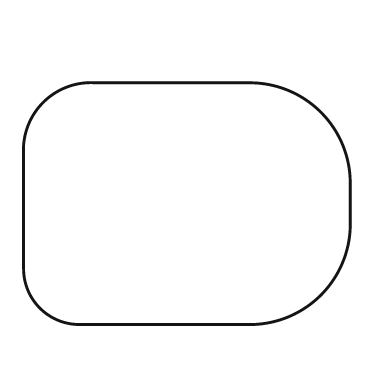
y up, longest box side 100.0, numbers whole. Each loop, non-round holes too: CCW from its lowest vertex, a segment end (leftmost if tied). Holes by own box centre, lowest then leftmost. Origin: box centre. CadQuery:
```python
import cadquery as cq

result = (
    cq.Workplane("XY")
    .moveTo(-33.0, -37.0)
    .lineTo(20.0, -37.0)
    .threePointArc((41.0, -28.0), (50.0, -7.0))
    .lineTo(50.0, 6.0)
    .threePointArc((41.0, 28.0), (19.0, 37.0))
    .lineTo(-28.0, 37.0)
    .threePointArc((-44.0, 31.0), (-50.0, 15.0))
    .lineTo(-50.0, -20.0)
    .threePointArc((-45.0, -32.0), (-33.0, -37.0))
    .close()
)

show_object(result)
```